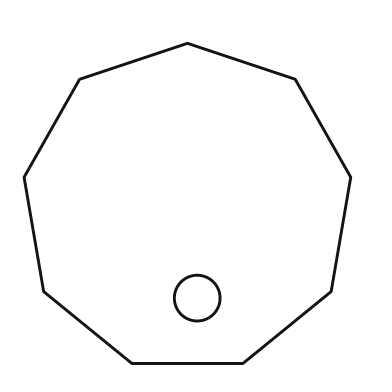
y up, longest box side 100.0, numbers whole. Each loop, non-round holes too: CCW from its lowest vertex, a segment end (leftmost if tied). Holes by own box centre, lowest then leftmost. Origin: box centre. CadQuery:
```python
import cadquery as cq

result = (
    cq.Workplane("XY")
    .moveTo(-17.0, -49.0)
    .lineTo(17.0, -49.0)
    .lineTo(44.0, -27.0)
    .lineTo(50.0, 8.0)
    .lineTo(33.0, 38.0)
    .lineTo(0.0, 49.0)
    .lineTo(-33.0, 38.0)
    .lineTo(-50.0, 8.0)
    .lineTo(-44.0, -27.0)
    .close()
    .moveTo(3.0, -29.0)
    .circle(7.0)
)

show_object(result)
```